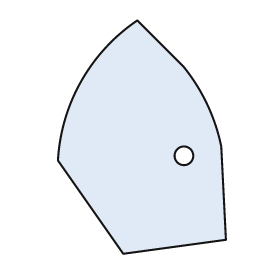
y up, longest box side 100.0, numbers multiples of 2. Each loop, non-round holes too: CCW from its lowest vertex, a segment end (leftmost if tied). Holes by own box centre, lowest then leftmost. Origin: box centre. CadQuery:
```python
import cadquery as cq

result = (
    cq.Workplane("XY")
    .moveTo(-8.0, -50.0)
    .lineTo(36.0, -44.0)
    .lineTo(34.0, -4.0)
    .threePointArc((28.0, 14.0), (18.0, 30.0))
    .lineTo(-2.0, 50.0)
    .threePointArc((-26.0, 24.0), (-36.0, -10.0))
    .close()
    .moveTo(18.0, -8.0)
    .circle(4.0)
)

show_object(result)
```